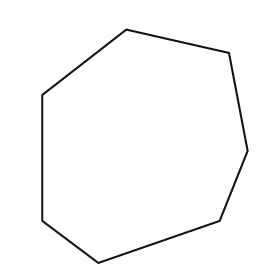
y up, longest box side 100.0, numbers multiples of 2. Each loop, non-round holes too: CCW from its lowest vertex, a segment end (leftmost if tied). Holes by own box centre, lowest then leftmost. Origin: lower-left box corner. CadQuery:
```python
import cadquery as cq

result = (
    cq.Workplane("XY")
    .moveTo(24.0, 0.0)
    .lineTo(76.0, 18.0)
    .lineTo(88.0, 48.0)
    .lineTo(80.0, 90.0)
    .lineTo(36.0, 100.0)
    .lineTo(0.0, 72.0)
    .lineTo(0.0, 18.0)
    .close()
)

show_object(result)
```